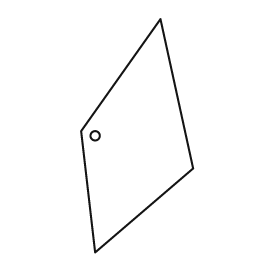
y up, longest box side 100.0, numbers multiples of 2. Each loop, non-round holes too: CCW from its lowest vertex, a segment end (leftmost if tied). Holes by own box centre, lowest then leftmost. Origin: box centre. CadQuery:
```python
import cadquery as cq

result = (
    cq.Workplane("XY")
    .moveTo(-18.0, -50.0)
    .lineTo(24.0, -14.0)
    .lineTo(10.0, 50.0)
    .lineTo(-24.0, 2.0)
    .close()
    .moveTo(-18.0, 0.0)
    .circle(2.0)
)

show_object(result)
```